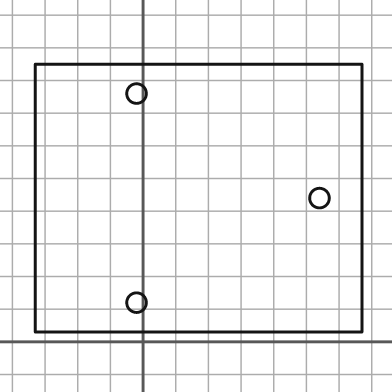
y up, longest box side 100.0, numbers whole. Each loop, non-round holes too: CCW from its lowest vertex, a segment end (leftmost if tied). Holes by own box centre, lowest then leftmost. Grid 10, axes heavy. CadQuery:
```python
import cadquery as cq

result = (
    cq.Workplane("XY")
    .moveTo(-33.0, 3.0)
    .lineTo(67.0, 3.0)
    .lineTo(67.0, 85.0)
    .lineTo(-33.0, 85.0)
    .close()
    .moveTo(-2.0, 12.0)
    .circle(3.0)
    .moveTo(54.0, 44.0)
    .circle(3.0)
    .moveTo(-2.0, 76.0)
    .circle(3.0)
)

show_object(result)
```